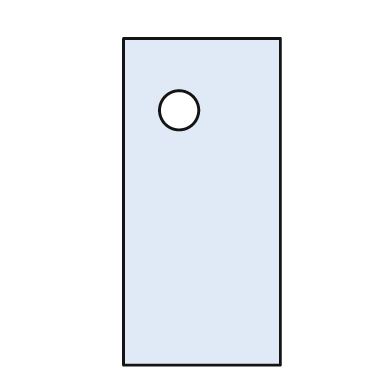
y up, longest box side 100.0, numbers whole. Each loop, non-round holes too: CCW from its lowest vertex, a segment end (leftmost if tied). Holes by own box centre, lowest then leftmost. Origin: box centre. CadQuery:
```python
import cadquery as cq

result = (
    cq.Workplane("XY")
    .moveTo(-24.0, -50.0)
    .lineTo(24.0, -50.0)
    .lineTo(24.0, 50.0)
    .lineTo(-24.0, 50.0)
    .close()
    .moveTo(-7.0, 28.0)
    .circle(6.0)
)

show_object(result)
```